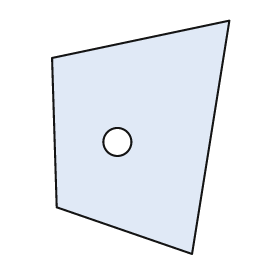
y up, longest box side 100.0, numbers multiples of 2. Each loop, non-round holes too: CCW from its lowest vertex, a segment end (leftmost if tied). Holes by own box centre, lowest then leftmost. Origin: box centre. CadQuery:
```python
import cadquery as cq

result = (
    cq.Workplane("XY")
    .moveTo(22.0, -50.0)
    .lineTo(38.0, 50.0)
    .lineTo(-38.0, 34.0)
    .lineTo(-36.0, -30.0)
    .close()
    .moveTo(-10.0, -2.0)
    .circle(6.0)
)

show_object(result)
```